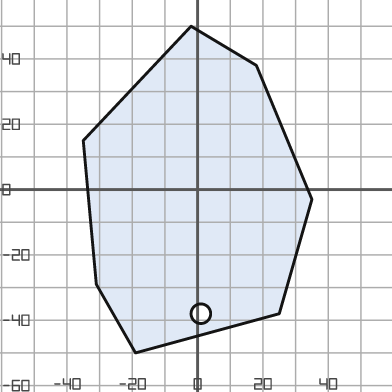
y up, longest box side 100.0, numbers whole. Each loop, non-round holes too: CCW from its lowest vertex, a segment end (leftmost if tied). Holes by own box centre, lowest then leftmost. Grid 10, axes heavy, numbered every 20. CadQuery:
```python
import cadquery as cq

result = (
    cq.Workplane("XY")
    .moveTo(-19.0, -50.0)
    .lineTo(25.0, -38.0)
    .lineTo(35.0, -3.0)
    .lineTo(18.0, 38.0)
    .lineTo(-2.0, 50.0)
    .lineTo(-35.0, 15.0)
    .lineTo(-31.0, -29.0)
    .close()
    .moveTo(1.0, -38.0)
    .circle(3.0)
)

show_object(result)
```